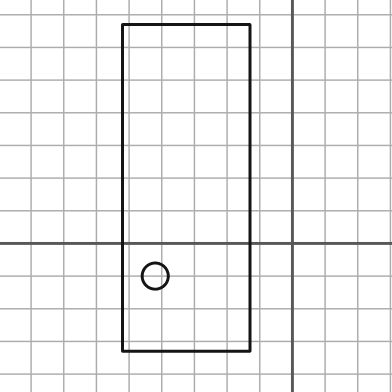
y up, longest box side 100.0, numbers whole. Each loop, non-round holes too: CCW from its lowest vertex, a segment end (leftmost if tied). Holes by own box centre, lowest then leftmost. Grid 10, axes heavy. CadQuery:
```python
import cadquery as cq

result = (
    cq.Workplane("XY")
    .moveTo(-52.0, -33.0)
    .lineTo(-13.0, -33.0)
    .lineTo(-13.0, 67.0)
    .lineTo(-52.0, 67.0)
    .close()
    .moveTo(-42.0, -10.0)
    .circle(4.0)
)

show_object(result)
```